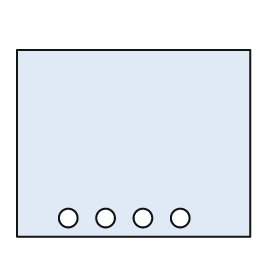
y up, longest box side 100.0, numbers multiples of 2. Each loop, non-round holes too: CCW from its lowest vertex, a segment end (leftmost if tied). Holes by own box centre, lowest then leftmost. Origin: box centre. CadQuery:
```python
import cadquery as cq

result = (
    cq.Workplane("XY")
    .moveTo(-50.0, -40.0)
    .lineTo(50.0, -40.0)
    .lineTo(50.0, 40.0)
    .lineTo(-50.0, 40.0)
    .close()
    .moveTo(-28.0, -32.0)
    .circle(4.0)
    .moveTo(-12.0, -32.0)
    .circle(4.0)
    .moveTo(4.0, -32.0)
    .circle(4.0)
    .moveTo(20.0, -32.0)
    .circle(4.0)
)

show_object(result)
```